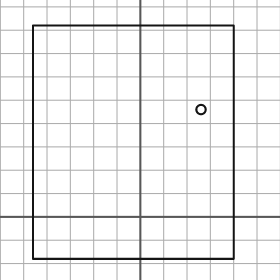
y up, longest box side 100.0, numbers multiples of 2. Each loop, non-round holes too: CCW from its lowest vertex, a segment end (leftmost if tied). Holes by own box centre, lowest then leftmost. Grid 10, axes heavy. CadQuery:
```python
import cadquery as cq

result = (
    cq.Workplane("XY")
    .moveTo(-46.0, -18.0)
    .lineTo(40.0, -18.0)
    .lineTo(40.0, 82.0)
    .lineTo(-46.0, 82.0)
    .close()
    .moveTo(26.0, 46.0)
    .circle(2.0)
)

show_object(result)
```